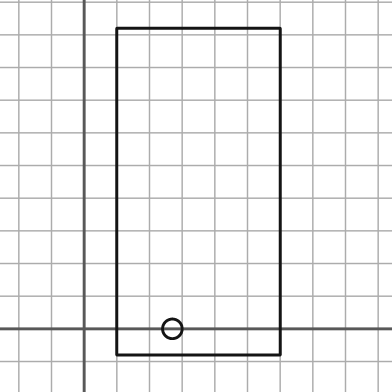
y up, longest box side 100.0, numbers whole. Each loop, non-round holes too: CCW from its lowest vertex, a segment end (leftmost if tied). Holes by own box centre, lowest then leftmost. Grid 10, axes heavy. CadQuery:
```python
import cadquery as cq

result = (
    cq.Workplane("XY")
    .moveTo(10.0, -8.0)
    .lineTo(60.0, -8.0)
    .lineTo(60.0, 92.0)
    .lineTo(10.0, 92.0)
    .close()
    .moveTo(27.0, 0.0)
    .circle(3.0)
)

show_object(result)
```